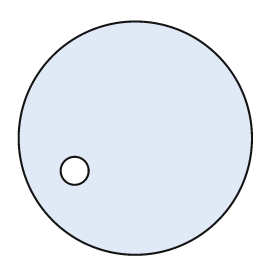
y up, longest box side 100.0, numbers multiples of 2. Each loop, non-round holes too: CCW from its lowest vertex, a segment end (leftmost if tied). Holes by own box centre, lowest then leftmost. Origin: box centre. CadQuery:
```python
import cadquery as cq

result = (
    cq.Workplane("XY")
    .moveTo(0.0, 0.0)
    .circle(50.0)
    .moveTo(-26.0, -14.0)
    .circle(6.0)
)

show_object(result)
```